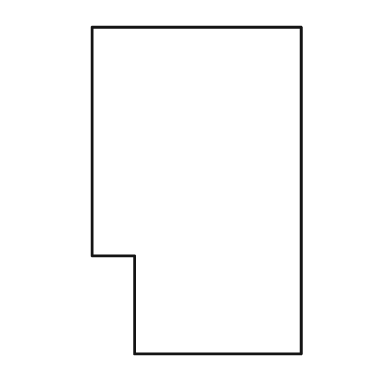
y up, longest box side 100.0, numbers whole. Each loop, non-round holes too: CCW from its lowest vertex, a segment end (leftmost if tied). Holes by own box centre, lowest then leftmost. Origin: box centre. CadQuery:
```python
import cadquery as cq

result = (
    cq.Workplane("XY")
    .moveTo(-19.0, -50.0)
    .lineTo(32.0, -50.0)
    .lineTo(32.0, 50.0)
    .lineTo(-32.0, 50.0)
    .lineTo(-32.0, -20.0)
    .lineTo(-19.0, -20.0)
    .close()
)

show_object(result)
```